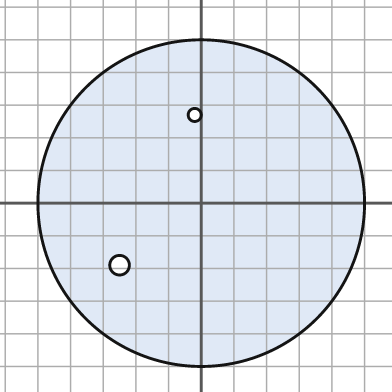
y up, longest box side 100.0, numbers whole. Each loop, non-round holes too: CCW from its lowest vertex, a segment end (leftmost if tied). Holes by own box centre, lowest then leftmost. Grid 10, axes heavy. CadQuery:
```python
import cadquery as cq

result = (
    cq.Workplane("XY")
    .moveTo(0.0, 0.0)
    .circle(50.0)
    .moveTo(-25.0, -19.0)
    .circle(3.0)
    .moveTo(-2.0, 27.0)
    .circle(2.0)
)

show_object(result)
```